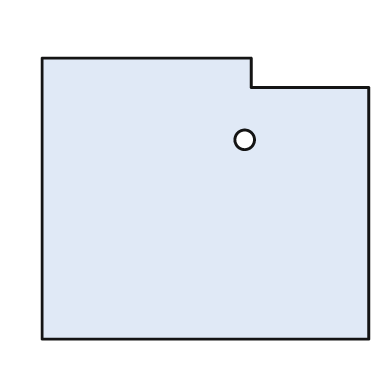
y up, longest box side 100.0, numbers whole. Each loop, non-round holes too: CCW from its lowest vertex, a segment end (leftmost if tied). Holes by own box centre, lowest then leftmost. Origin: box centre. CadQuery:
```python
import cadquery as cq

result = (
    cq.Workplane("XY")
    .moveTo(-50.0, -43.0)
    .lineTo(50.0, -43.0)
    .lineTo(50.0, 34.0)
    .lineTo(14.0, 34.0)
    .lineTo(14.0, 43.0)
    .lineTo(-50.0, 43.0)
    .close()
    .moveTo(12.0, 18.0)
    .circle(3.0)
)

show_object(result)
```